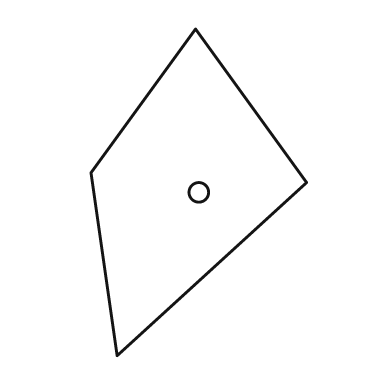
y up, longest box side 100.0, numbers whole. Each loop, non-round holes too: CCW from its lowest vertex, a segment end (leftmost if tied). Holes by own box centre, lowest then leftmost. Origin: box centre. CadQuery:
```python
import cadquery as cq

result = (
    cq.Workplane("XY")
    .moveTo(-25.0, -50.0)
    .lineTo(33.0, 3.0)
    .lineTo(-1.0, 50.0)
    .lineTo(-33.0, 6.0)
    .close()
    .moveTo(0.0, 0.0)
    .circle(3.0)
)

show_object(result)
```